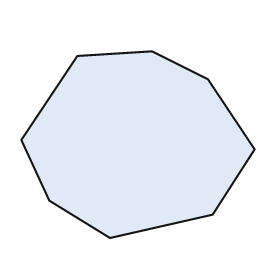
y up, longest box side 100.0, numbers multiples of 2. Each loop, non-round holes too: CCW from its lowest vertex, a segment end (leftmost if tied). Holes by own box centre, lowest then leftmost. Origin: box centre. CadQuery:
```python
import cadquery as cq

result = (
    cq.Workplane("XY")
    .moveTo(-12.0, -40.0)
    .lineTo(32.0, -30.0)
    .lineTo(50.0, -2.0)
    .lineTo(30.0, 28.0)
    .lineTo(6.0, 40.0)
    .lineTo(-26.0, 38.0)
    .lineTo(-50.0, 2.0)
    .lineTo(-38.0, -24.0)
    .close()
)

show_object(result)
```